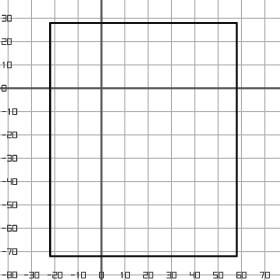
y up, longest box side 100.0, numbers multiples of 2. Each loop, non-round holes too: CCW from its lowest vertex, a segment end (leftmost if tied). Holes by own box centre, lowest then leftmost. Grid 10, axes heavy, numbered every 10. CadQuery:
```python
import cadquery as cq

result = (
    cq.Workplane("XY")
    .moveTo(-22.0, -72.0)
    .lineTo(58.0, -72.0)
    .lineTo(58.0, 28.0)
    .lineTo(-22.0, 28.0)
    .close()
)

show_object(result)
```